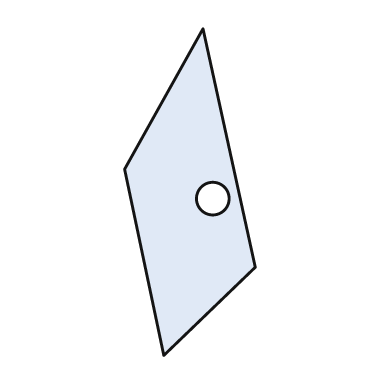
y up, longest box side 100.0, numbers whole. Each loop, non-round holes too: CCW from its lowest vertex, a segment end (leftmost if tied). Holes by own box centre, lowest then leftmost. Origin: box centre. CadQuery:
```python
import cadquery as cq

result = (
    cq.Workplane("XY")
    .moveTo(-8.0, -50.0)
    .lineTo(20.0, -23.0)
    .lineTo(4.0, 50.0)
    .lineTo(-20.0, 7.0)
    .close()
    .moveTo(7.0, -2.0)
    .circle(5.0)
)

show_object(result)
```